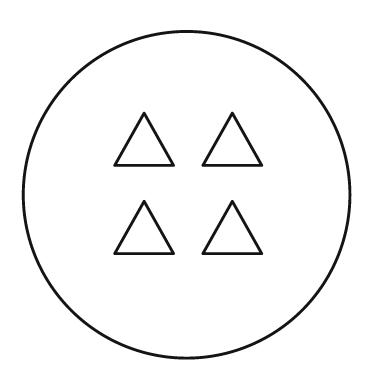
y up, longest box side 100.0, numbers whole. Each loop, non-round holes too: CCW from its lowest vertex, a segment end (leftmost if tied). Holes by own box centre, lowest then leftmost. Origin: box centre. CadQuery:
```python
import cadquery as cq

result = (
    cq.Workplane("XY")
    .moveTo(0.0, 0.0)
    .circle(50.0)
    .moveTo(-22.0, -18.0)
    .lineTo(-4.0, -18.0)
    .lineTo(-13.0, -2.0)
    .close()
    .moveTo(5.0, -18.0)
    .lineTo(23.0, -18.0)
    .lineTo(14.0, -2.0)
    .close()
    .moveTo(-22.0, 9.0)
    .lineTo(-4.0, 9.0)
    .lineTo(-13.0, 25.0)
    .close()
    .moveTo(5.0, 9.0)
    .lineTo(23.0, 9.0)
    .lineTo(14.0, 25.0)
    .close()
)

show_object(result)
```